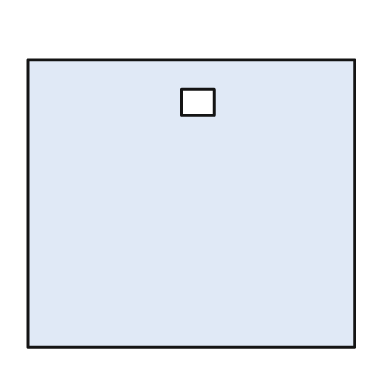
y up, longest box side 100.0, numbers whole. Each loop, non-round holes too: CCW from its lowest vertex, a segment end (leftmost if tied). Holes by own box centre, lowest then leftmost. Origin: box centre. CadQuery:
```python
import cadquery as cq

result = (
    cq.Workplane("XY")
    .moveTo(-50.0, -44.0)
    .lineTo(50.0, -44.0)
    .lineTo(50.0, 44.0)
    .lineTo(-50.0, 44.0)
    .close()
    .moveTo(-3.0, 27.0)
    .lineTo(7.0, 27.0)
    .lineTo(7.0, 35.0)
    .lineTo(-3.0, 35.0)
    .close()
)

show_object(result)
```